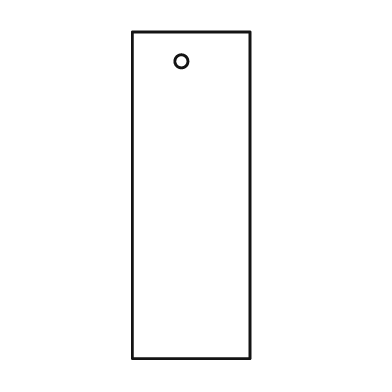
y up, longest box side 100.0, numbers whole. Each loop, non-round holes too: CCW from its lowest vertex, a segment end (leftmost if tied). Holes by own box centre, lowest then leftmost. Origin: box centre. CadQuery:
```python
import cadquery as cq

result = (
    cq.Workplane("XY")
    .moveTo(-18.0, -50.0)
    .lineTo(18.0, -50.0)
    .lineTo(18.0, 50.0)
    .lineTo(-18.0, 50.0)
    .close()
    .moveTo(-3.0, 41.0)
    .circle(2.0)
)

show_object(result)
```